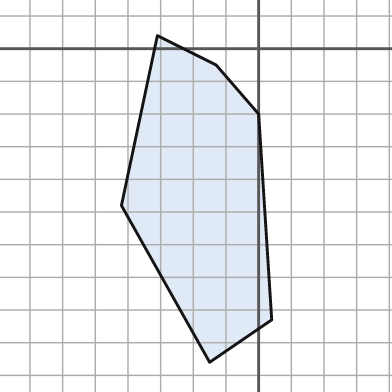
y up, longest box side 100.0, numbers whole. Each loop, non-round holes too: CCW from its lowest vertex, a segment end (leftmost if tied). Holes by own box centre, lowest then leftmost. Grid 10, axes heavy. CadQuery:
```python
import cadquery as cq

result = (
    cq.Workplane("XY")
    .moveTo(-15.0, -96.0)
    .lineTo(4.0, -83.0)
    .lineTo(0.0, -20.0)
    .lineTo(-13.0, -5.0)
    .lineTo(-31.0, 4.0)
    .lineTo(-42.0, -48.0)
    .close()
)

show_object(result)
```